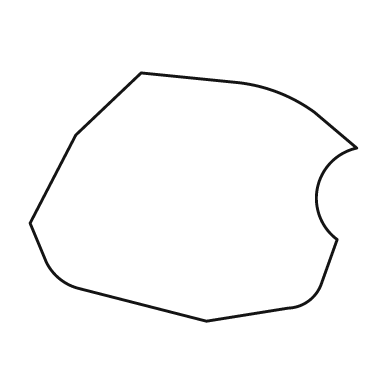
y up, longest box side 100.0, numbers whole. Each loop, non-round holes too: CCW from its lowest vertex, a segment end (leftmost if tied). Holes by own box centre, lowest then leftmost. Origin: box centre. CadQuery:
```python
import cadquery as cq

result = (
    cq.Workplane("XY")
    .moveTo(4.0, -38.0)
    .lineTo(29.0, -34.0)
    .threePointArc((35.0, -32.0), (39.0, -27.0))
    .lineTo(44.0, -13.0)
    .threePointArc((38.0, 3.0), (50.0, 15.0))
    .lineTo(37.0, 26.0)
    .threePointArc((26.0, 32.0), (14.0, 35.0))
    .lineTo(-16.0, 38.0)
    .lineTo(-36.0, 19.0)
    .lineTo(-50.0, -8.0)
    .lineTo(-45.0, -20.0)
    .threePointArc((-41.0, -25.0), (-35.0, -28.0))
    .close()
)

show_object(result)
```